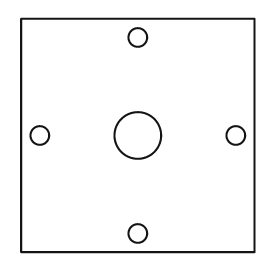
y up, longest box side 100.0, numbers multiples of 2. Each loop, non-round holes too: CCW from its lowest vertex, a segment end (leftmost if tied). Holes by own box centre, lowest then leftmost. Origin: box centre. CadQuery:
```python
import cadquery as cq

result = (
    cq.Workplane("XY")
    .moveTo(-50.0, -50.0)
    .lineTo(50.0, -50.0)
    .lineTo(50.0, 50.0)
    .lineTo(-50.0, 50.0)
    .close()
    .moveTo(0.0, -42.0)
    .circle(4.0)
    .moveTo(-42.0, 0.0)
    .circle(4.0)
    .moveTo(0.0, 0.0)
    .circle(10.0)
    .moveTo(42.0, 0.0)
    .circle(4.0)
    .moveTo(0.0, 42.0)
    .circle(4.0)
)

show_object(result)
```